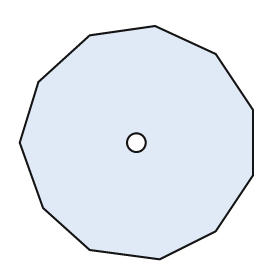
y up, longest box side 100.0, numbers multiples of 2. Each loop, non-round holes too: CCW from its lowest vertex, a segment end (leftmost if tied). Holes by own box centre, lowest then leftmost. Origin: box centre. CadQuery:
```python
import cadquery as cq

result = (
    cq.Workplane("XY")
    .moveTo(10.0, -50.0)
    .lineTo(34.0, -38.0)
    .lineTo(50.0, -14.0)
    .lineTo(50.0, 14.0)
    .lineTo(34.0, 38.0)
    .lineTo(8.0, 50.0)
    .lineTo(-20.0, 46.0)
    .lineTo(-42.0, 26.0)
    .lineTo(-50.0, 0.0)
    .lineTo(-40.0, -28.0)
    .lineTo(-20.0, -46.0)
    .close()
    .moveTo(0.0, 0.0)
    .circle(4.0)
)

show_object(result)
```